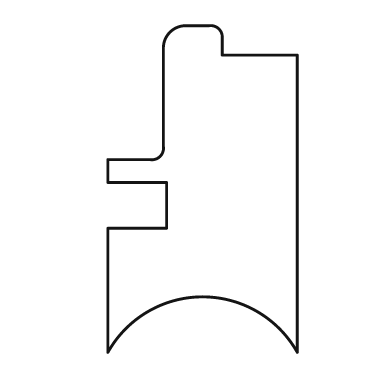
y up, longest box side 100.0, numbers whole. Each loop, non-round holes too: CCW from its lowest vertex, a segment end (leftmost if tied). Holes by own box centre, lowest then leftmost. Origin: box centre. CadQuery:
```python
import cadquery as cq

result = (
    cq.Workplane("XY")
    .moveTo(-29.0, -50.0)
    .threePointArc((0.0, -33.0), (29.0, -50.0))
    .lineTo(29.0, 41.0)
    .lineTo(6.0, 41.0)
    .lineTo(6.0, 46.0)
    .threePointArc((5.0, 49.0), (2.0, 50.0))
    .lineTo(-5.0, 50.0)
    .threePointArc((-10.0, 48.0), (-12.0, 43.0))
    .lineTo(-12.0, 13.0)
    .threePointArc((-13.0, 10.0), (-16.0, 9.0))
    .lineTo(-29.0, 9.0)
    .lineTo(-29.0, 2.0)
    .lineTo(-11.0, 2.0)
    .lineTo(-11.0, -12.0)
    .lineTo(-29.0, -12.0)
    .close()
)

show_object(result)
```